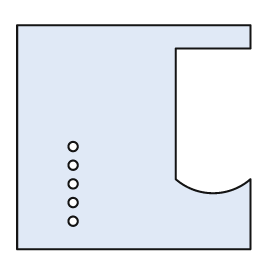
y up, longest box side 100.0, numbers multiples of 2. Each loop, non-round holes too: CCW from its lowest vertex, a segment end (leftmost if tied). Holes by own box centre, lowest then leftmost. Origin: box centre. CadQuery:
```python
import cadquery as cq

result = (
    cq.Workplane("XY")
    .moveTo(-50.0, -48.0)
    .lineTo(50.0, -48.0)
    .lineTo(50.0, -18.0)
    .threePointArc((34.0, -24.0), (18.0, -18.0))
    .lineTo(18.0, 38.0)
    .lineTo(50.0, 38.0)
    .lineTo(50.0, 48.0)
    .lineTo(-50.0, 48.0)
    .close()
    .moveTo(-26.0, -36.0)
    .circle(2.0)
    .moveTo(-26.0, -28.0)
    .circle(2.0)
    .moveTo(-26.0, -20.0)
    .circle(2.0)
    .moveTo(-26.0, -12.0)
    .circle(2.0)
    .moveTo(-26.0, -4.0)
    .circle(2.0)
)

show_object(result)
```